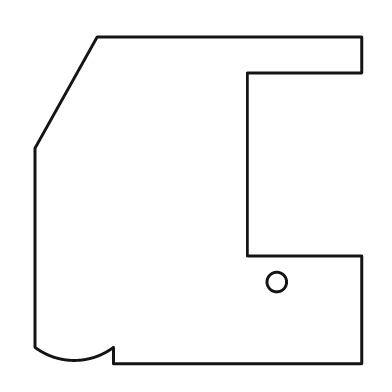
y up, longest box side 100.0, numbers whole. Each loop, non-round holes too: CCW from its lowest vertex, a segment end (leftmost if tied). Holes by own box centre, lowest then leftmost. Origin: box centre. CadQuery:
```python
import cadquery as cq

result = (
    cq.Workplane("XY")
    .moveTo(-26.0, -50.0)
    .lineTo(50.0, -50.0)
    .lineTo(50.0, -17.0)
    .lineTo(15.0, -17.0)
    .lineTo(15.0, 39.0)
    .lineTo(50.0, 39.0)
    .lineTo(50.0, 50.0)
    .lineTo(-31.0, 50.0)
    .lineTo(-50.0, 16.0)
    .lineTo(-50.0, -45.0)
    .threePointArc((-38.0, -49.0), (-26.0, -45.0))
    .close()
    .moveTo(24.0, -25.0)
    .circle(3.0)
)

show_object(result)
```